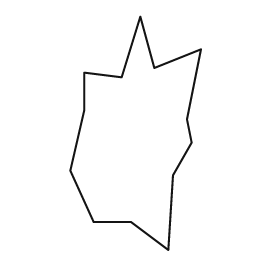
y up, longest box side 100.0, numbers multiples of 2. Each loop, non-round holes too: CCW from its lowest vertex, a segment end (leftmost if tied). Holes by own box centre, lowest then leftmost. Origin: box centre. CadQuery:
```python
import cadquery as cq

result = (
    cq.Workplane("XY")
    .moveTo(14.0, -50.0)
    .lineTo(16.0, -18.0)
    .lineTo(24.0, -4.0)
    .lineTo(22.0, 6.0)
    .lineTo(28.0, 36.0)
    .lineTo(8.0, 28.0)
    .lineTo(2.0, 50.0)
    .lineTo(-6.0, 24.0)
    .lineTo(-22.0, 26.0)
    .lineTo(-22.0, 10.0)
    .lineTo(-28.0, -16.0)
    .lineTo(-18.0, -38.0)
    .lineTo(-2.0, -38.0)
    .close()
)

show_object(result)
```